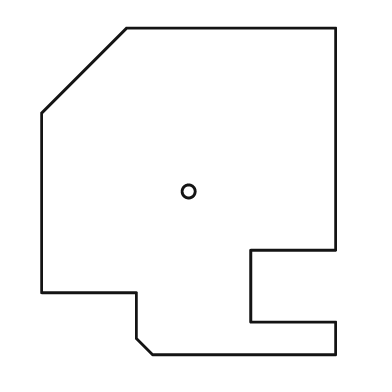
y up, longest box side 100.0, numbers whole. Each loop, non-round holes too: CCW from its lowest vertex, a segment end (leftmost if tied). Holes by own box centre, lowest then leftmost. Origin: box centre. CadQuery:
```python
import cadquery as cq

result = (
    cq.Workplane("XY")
    .moveTo(-11.0, -50.0)
    .lineTo(45.0, -50.0)
    .lineTo(45.0, -40.0)
    .lineTo(19.0, -40.0)
    .lineTo(19.0, -18.0)
    .lineTo(45.0, -18.0)
    .lineTo(45.0, 50.0)
    .lineTo(-19.0, 50.0)
    .lineTo(-45.0, 24.0)
    .lineTo(-45.0, -31.0)
    .lineTo(-16.0, -31.0)
    .lineTo(-16.0, -45.0)
    .close()
    .moveTo(0.0, 0.0)
    .circle(2.0)
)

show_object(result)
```